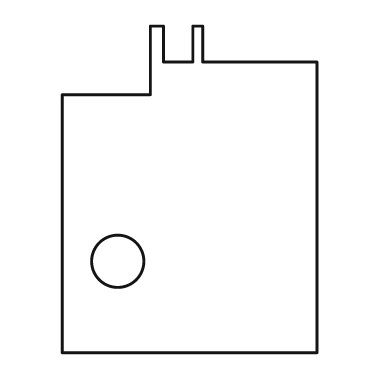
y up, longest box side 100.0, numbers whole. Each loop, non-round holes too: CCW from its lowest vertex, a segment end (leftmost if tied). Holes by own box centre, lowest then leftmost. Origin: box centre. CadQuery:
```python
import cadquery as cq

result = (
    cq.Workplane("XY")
    .moveTo(-39.0, -50.0)
    .lineTo(39.0, -50.0)
    .lineTo(39.0, 39.0)
    .lineTo(4.0, 39.0)
    .lineTo(4.0, 50.0)
    .lineTo(1.0, 50.0)
    .lineTo(1.0, 39.0)
    .lineTo(-8.0, 39.0)
    .lineTo(-8.0, 50.0)
    .lineTo(-12.0, 50.0)
    .lineTo(-12.0, 29.0)
    .lineTo(-39.0, 29.0)
    .close()
    .moveTo(-22.0, -22.0)
    .circle(8.0)
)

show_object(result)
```